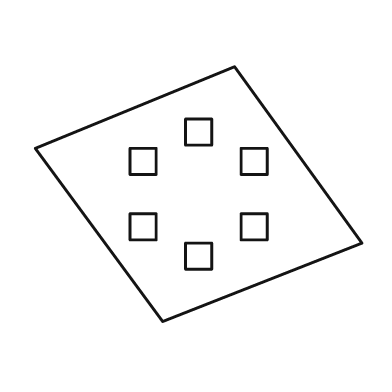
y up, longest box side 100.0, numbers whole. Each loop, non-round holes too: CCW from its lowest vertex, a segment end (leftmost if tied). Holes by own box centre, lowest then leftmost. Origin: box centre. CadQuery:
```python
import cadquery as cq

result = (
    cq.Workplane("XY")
    .moveTo(-11.0, -39.0)
    .lineTo(50.0, -15.0)
    .lineTo(11.0, 39.0)
    .lineTo(-50.0, 14.0)
    .close()
    .moveTo(-4.0, -23.0)
    .lineTo(4.0, -23.0)
    .lineTo(4.0, -15.0)
    .lineTo(-4.0, -15.0)
    .close()
    .moveTo(-21.0, -14.0)
    .lineTo(-13.0, -14.0)
    .lineTo(-13.0, -6.0)
    .lineTo(-21.0, -6.0)
    .close()
    .moveTo(13.0, -14.0)
    .lineTo(21.0, -14.0)
    .lineTo(21.0, -6.0)
    .lineTo(13.0, -6.0)
    .close()
    .moveTo(-21.0, 6.0)
    .lineTo(-13.0, 6.0)
    .lineTo(-13.0, 14.0)
    .lineTo(-21.0, 14.0)
    .close()
    .moveTo(13.0, 6.0)
    .lineTo(21.0, 6.0)
    .lineTo(21.0, 14.0)
    .lineTo(13.0, 14.0)
    .close()
    .moveTo(-4.0, 15.0)
    .lineTo(4.0, 15.0)
    .lineTo(4.0, 23.0)
    .lineTo(-4.0, 23.0)
    .close()
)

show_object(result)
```